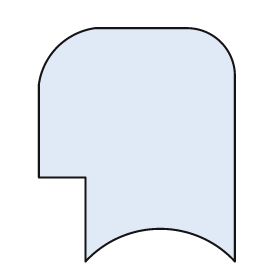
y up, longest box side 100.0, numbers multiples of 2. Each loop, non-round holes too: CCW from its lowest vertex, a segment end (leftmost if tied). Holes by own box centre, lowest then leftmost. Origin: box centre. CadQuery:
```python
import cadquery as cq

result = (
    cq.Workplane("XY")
    .moveTo(-22.0, -50.0)
    .threePointArc((10.0, -36.0), (42.0, -50.0))
    .lineTo(42.0, 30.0)
    .threePointArc((36.0, 44.0), (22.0, 50.0))
    .lineTo(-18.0, 50.0)
    .threePointArc((-34.0, 42.0), (-42.0, 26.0))
    .lineTo(-42.0, -14.0)
    .lineTo(-22.0, -14.0)
    .close()
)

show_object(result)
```